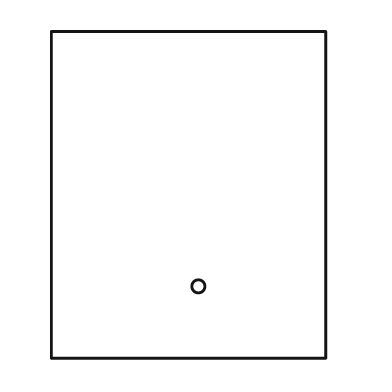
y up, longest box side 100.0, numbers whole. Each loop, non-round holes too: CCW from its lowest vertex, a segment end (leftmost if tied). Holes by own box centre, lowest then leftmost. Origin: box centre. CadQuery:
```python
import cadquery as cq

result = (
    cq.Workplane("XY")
    .moveTo(-42.0, -50.0)
    .lineTo(42.0, -50.0)
    .lineTo(42.0, 50.0)
    .lineTo(-42.0, 50.0)
    .close()
    .moveTo(3.0, -28.0)
    .circle(2.0)
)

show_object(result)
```